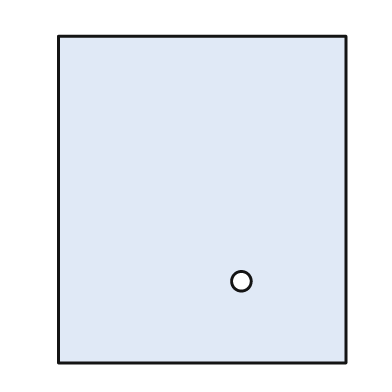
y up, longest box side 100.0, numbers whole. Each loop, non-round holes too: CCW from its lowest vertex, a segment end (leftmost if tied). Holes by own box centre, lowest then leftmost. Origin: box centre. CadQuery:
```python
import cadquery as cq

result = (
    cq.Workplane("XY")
    .moveTo(-44.0, -50.0)
    .lineTo(44.0, -50.0)
    .lineTo(44.0, 50.0)
    .lineTo(-44.0, 50.0)
    .close()
    .moveTo(12.0, -25.0)
    .circle(3.0)
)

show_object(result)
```